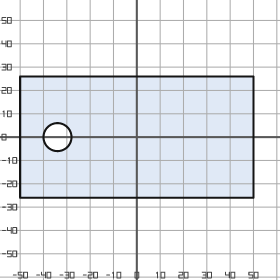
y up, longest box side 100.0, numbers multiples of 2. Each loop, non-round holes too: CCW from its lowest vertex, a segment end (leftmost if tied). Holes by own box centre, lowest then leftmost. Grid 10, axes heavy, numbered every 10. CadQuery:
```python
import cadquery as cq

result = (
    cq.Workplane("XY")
    .moveTo(-50.0, -26.0)
    .lineTo(50.0, -26.0)
    .lineTo(50.0, 26.0)
    .lineTo(-50.0, 26.0)
    .close()
    .moveTo(-34.0, 0.0)
    .circle(6.0)
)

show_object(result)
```